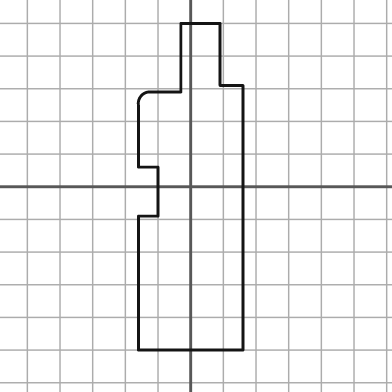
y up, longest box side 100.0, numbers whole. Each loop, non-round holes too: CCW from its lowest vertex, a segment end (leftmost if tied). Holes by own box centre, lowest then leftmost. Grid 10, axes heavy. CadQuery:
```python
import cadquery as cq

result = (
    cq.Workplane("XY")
    .moveTo(-16.0, -50.0)
    .lineTo(16.0, -50.0)
    .lineTo(16.0, 31.0)
    .lineTo(9.0, 31.0)
    .lineTo(9.0, 50.0)
    .lineTo(-3.0, 50.0)
    .lineTo(-3.0, 29.0)
    .lineTo(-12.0, 29.0)
    .threePointArc((-15.0, 28.0), (-16.0, 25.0))
    .lineTo(-16.0, 6.0)
    .lineTo(-10.0, 6.0)
    .lineTo(-10.0, -9.0)
    .lineTo(-16.0, -9.0)
    .close()
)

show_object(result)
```